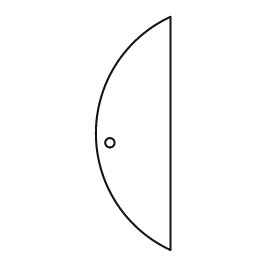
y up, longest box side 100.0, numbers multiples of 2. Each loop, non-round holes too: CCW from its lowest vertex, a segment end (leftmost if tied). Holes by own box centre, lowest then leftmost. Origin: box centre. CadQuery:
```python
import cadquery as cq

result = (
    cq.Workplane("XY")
    .moveTo(16.0, -50.0)
    .lineTo(16.0, 50.0)
    .threePointArc((-16.0, 0.0), (16.0, -50.0))
    .close()
    .moveTo(-10.0, -4.0)
    .circle(2.0)
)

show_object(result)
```